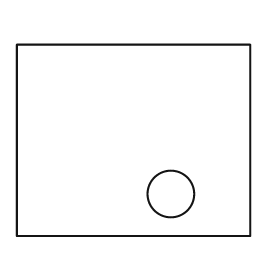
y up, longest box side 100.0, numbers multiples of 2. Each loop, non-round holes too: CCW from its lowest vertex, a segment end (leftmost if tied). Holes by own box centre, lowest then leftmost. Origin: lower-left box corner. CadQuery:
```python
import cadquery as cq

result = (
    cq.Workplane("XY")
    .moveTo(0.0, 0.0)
    .lineTo(100.0, 0.0)
    .lineTo(100.0, 82.0)
    .lineTo(0.0, 82.0)
    .close()
    .moveTo(66.0, 18.0)
    .circle(10.0)
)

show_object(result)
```